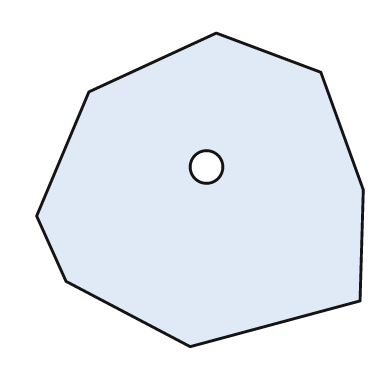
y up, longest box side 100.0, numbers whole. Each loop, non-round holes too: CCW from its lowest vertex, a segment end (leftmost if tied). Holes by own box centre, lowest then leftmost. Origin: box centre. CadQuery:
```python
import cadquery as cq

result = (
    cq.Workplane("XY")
    .moveTo(-3.0, -48.0)
    .lineTo(49.0, -34.0)
    .lineTo(50.0, 0.0)
    .lineTo(37.0, 36.0)
    .lineTo(5.0, 48.0)
    .lineTo(-34.0, 30.0)
    .lineTo(-50.0, -8.0)
    .lineTo(-41.0, -28.0)
    .close()
    .moveTo(2.0, 7.0)
    .circle(5.0)
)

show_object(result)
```